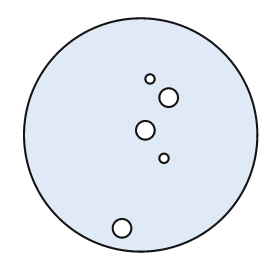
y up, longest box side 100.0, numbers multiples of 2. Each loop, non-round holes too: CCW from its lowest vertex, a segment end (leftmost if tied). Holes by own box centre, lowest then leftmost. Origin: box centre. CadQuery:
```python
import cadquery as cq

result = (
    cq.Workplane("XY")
    .moveTo(0.0, 0.0)
    .circle(50.0)
    .moveTo(-8.0, -40.0)
    .circle(4.0)
    .moveTo(10.0, -10.0)
    .circle(2.0)
    .moveTo(2.0, 2.0)
    .circle(4.0)
    .moveTo(12.0, 16.0)
    .circle(4.0)
    .moveTo(4.0, 24.0)
    .circle(2.0)
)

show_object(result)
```